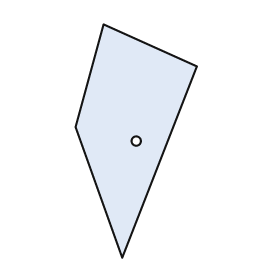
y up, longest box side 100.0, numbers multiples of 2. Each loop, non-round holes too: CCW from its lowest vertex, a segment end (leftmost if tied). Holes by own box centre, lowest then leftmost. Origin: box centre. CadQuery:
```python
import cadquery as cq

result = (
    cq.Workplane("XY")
    .moveTo(-6.0, -50.0)
    .lineTo(26.0, 32.0)
    .lineTo(-14.0, 50.0)
    .lineTo(-26.0, 6.0)
    .close()
    .moveTo(0.0, 0.0)
    .circle(2.0)
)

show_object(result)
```